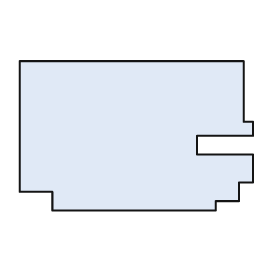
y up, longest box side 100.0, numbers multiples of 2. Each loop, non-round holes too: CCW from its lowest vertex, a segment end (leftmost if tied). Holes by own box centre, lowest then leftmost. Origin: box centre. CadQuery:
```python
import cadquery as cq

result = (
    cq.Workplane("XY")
    .moveTo(-36.0, -32.0)
    .lineTo(34.0, -32.0)
    .lineTo(34.0, -28.0)
    .lineTo(44.0, -28.0)
    .lineTo(44.0, -20.0)
    .lineTo(50.0, -20.0)
    .lineTo(50.0, -8.0)
    .lineTo(26.0, -8.0)
    .lineTo(26.0, 0.0)
    .lineTo(50.0, 0.0)
    .lineTo(50.0, 6.0)
    .lineTo(46.0, 6.0)
    .lineTo(46.0, 32.0)
    .lineTo(-50.0, 32.0)
    .lineTo(-50.0, -24.0)
    .lineTo(-36.0, -24.0)
    .close()
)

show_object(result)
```